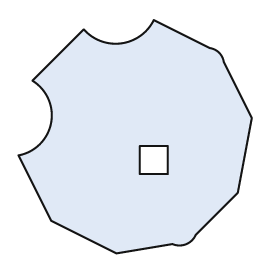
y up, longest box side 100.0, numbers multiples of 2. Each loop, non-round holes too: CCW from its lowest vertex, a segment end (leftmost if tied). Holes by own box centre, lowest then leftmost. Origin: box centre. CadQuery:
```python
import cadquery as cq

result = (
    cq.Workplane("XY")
    .moveTo(-8.0, -50.0)
    .lineTo(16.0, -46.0)
    .threePointArc((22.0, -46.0), (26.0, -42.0))
    .lineTo(44.0, -24.0)
    .lineTo(50.0, 8.0)
    .lineTo(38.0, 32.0)
    .threePointArc((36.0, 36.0), (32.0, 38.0))
    .lineTo(8.0, 50.0)
    .threePointArc((-6.0, 40.0), (-22.0, 46.0))
    .lineTo(-44.0, 24.0)
    .threePointArc((-36.0, 6.0), (-50.0, -8.0))
    .lineTo(-36.0, -36.0)
    .close()
    .moveTo(2.0, -16.0)
    .lineTo(14.0, -16.0)
    .lineTo(14.0, -4.0)
    .lineTo(2.0, -4.0)
    .close()
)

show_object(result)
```